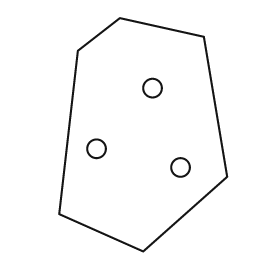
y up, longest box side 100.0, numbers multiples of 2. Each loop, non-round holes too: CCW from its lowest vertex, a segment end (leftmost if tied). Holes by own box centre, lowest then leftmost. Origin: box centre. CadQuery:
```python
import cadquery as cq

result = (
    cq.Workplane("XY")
    .moveTo(0.0, -50.0)
    .lineTo(36.0, -18.0)
    .lineTo(26.0, 42.0)
    .lineTo(-10.0, 50.0)
    .lineTo(-28.0, 36.0)
    .lineTo(-36.0, -34.0)
    .close()
    .moveTo(16.0, -14.0)
    .circle(4.0)
    .moveTo(-20.0, -6.0)
    .circle(4.0)
    .moveTo(4.0, 20.0)
    .circle(4.0)
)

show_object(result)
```